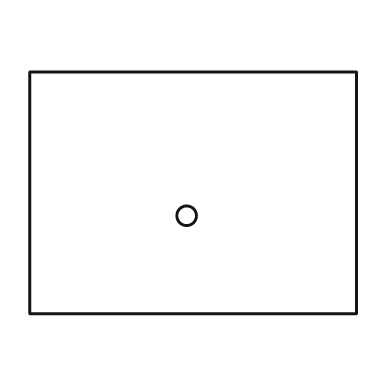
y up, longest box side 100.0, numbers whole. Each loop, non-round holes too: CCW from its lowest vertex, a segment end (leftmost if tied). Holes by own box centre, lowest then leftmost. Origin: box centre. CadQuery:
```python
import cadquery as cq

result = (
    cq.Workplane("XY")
    .moveTo(-50.0, -37.0)
    .lineTo(50.0, -37.0)
    .lineTo(50.0, 37.0)
    .lineTo(-50.0, 37.0)
    .close()
    .moveTo(-2.0, -7.0)
    .circle(3.0)
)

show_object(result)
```